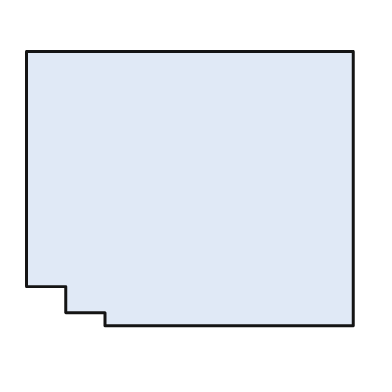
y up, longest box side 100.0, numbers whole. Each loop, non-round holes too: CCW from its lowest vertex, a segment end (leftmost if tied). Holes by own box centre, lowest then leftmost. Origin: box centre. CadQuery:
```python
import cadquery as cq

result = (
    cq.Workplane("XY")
    .moveTo(-26.0, -42.0)
    .lineTo(50.0, -42.0)
    .lineTo(50.0, 42.0)
    .lineTo(-50.0, 42.0)
    .lineTo(-50.0, -30.0)
    .lineTo(-38.0, -30.0)
    .lineTo(-38.0, -38.0)
    .lineTo(-26.0, -38.0)
    .close()
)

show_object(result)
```